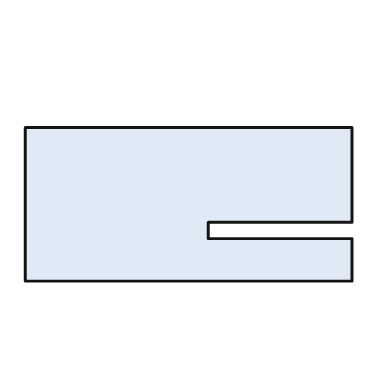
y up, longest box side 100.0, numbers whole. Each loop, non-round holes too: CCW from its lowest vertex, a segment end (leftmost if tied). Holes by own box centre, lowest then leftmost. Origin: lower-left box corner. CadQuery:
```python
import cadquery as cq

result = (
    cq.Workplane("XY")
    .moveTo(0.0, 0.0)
    .lineTo(100.0, 0.0)
    .lineTo(100.0, 13.0)
    .lineTo(56.0, 13.0)
    .lineTo(56.0, 18.0)
    .lineTo(100.0, 18.0)
    .lineTo(100.0, 47.0)
    .lineTo(0.0, 47.0)
    .close()
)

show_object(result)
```